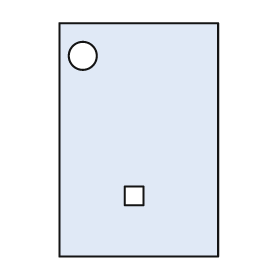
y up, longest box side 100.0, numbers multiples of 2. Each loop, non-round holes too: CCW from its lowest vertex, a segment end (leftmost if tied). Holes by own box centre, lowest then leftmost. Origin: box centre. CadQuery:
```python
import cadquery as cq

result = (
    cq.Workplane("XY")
    .moveTo(-34.0, -50.0)
    .lineTo(34.0, -50.0)
    .lineTo(34.0, 50.0)
    .lineTo(-34.0, 50.0)
    .close()
    .moveTo(-6.0, -28.0)
    .lineTo(2.0, -28.0)
    .lineTo(2.0, -20.0)
    .lineTo(-6.0, -20.0)
    .close()
    .moveTo(-24.0, 36.0)
    .circle(6.0)
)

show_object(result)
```